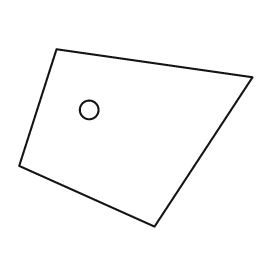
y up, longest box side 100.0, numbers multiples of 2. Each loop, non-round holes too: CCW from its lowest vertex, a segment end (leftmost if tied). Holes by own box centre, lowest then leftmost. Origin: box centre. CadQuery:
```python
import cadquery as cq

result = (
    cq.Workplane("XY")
    .moveTo(8.0, -38.0)
    .lineTo(50.0, 26.0)
    .lineTo(-34.0, 38.0)
    .lineTo(-50.0, -12.0)
    .close()
    .moveTo(-20.0, 12.0)
    .circle(4.0)
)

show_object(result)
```